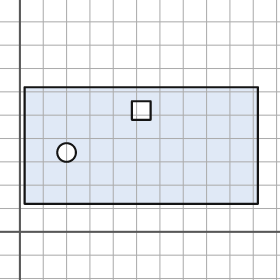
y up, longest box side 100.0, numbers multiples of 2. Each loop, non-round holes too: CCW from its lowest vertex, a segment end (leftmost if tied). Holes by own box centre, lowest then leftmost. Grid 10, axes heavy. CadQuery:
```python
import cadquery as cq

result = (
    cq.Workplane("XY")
    .moveTo(2.0, 12.0)
    .lineTo(102.0, 12.0)
    .lineTo(102.0, 62.0)
    .lineTo(2.0, 62.0)
    .close()
    .moveTo(20.0, 34.0)
    .circle(4.0)
    .moveTo(48.0, 48.0)
    .lineTo(56.0, 48.0)
    .lineTo(56.0, 56.0)
    .lineTo(48.0, 56.0)
    .close()
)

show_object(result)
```